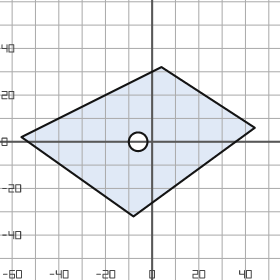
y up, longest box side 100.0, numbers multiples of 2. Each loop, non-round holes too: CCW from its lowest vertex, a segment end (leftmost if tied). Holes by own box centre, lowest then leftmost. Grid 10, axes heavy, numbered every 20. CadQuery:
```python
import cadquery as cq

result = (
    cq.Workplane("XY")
    .moveTo(-8.0, -32.0)
    .lineTo(44.0, 6.0)
    .lineTo(4.0, 32.0)
    .lineTo(-56.0, 2.0)
    .close()
    .moveTo(-6.0, 0.0)
    .circle(4.0)
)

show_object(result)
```